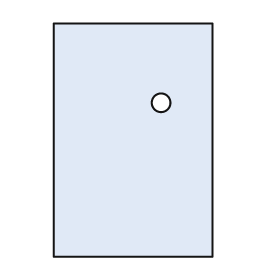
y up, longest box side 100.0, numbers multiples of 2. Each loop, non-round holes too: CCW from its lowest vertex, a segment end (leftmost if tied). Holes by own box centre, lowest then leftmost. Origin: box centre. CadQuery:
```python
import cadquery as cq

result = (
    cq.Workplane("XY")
    .moveTo(-34.0, -50.0)
    .lineTo(34.0, -50.0)
    .lineTo(34.0, 50.0)
    .lineTo(-34.0, 50.0)
    .close()
    .moveTo(12.0, 16.0)
    .circle(4.0)
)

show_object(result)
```